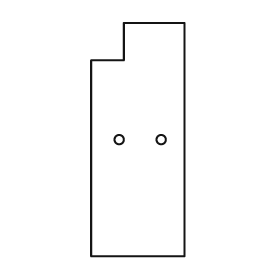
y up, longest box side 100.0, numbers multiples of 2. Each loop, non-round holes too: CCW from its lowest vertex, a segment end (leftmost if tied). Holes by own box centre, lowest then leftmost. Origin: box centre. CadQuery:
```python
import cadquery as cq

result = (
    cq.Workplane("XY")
    .moveTo(-20.0, -50.0)
    .lineTo(20.0, -50.0)
    .lineTo(20.0, 50.0)
    .lineTo(-6.0, 50.0)
    .lineTo(-6.0, 34.0)
    .lineTo(-20.0, 34.0)
    .close()
    .moveTo(-8.0, 0.0)
    .circle(2.0)
    .moveTo(10.0, 0.0)
    .circle(2.0)
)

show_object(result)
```